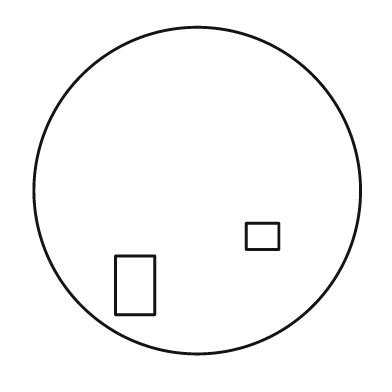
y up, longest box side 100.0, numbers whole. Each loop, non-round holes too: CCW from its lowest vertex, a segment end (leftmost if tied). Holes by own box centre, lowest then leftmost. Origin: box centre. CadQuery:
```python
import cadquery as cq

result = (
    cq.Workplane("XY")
    .moveTo(0.0, 0.0)
    .circle(50.0)
    .moveTo(-25.0, -38.0)
    .lineTo(-13.0, -38.0)
    .lineTo(-13.0, -20.0)
    .lineTo(-25.0, -20.0)
    .close()
    .moveTo(15.0, -18.0)
    .lineTo(25.0, -18.0)
    .lineTo(25.0, -10.0)
    .lineTo(15.0, -10.0)
    .close()
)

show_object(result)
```